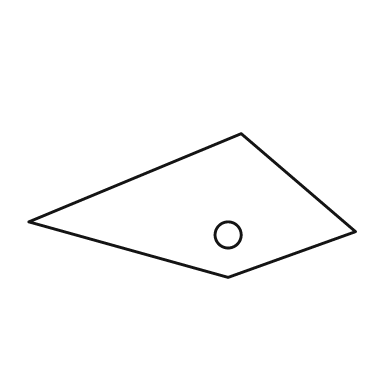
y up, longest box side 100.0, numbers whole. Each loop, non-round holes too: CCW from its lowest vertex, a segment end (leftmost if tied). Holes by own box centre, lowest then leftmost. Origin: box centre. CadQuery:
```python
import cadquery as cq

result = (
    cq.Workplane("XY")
    .moveTo(11.0, -22.0)
    .lineTo(50.0, -8.0)
    .lineTo(15.0, 22.0)
    .lineTo(-50.0, -5.0)
    .close()
    .moveTo(11.0, -9.0)
    .circle(4.0)
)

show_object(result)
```